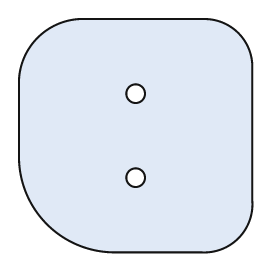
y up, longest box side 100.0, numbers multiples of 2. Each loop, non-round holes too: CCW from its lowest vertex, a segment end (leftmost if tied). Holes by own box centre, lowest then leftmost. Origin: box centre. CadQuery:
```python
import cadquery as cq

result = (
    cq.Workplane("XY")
    .moveTo(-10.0, -50.0)
    .lineTo(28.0, -50.0)
    .threePointArc((44.0, -44.0), (50.0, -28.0))
    .lineTo(50.0, 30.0)
    .threePointArc((44.0, 44.0), (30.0, 50.0))
    .lineTo(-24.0, 50.0)
    .threePointArc((-42.0, 42.0), (-50.0, 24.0))
    .lineTo(-50.0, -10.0)
    .threePointArc((-38.0, -38.0), (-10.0, -50.0))
    .close()
    .moveTo(0.0, -18.0)
    .circle(4.0)
    .moveTo(0.0, 18.0)
    .circle(4.0)
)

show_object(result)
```